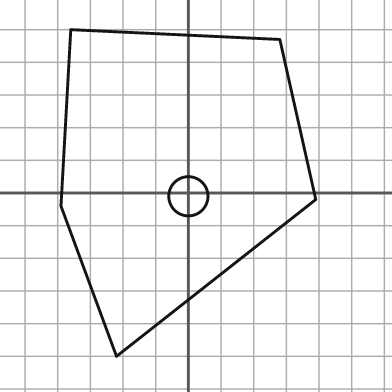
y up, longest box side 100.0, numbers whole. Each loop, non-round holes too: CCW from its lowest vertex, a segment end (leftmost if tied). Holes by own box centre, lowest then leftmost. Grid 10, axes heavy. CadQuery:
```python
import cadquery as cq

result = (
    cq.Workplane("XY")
    .moveTo(-22.0, -50.0)
    .lineTo(39.0, -2.0)
    .lineTo(28.0, 47.0)
    .lineTo(-36.0, 50.0)
    .lineTo(-39.0, -4.0)
    .close()
    .moveTo(0.0, -1.0)
    .circle(6.0)
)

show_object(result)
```